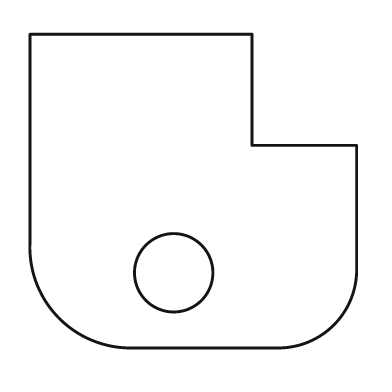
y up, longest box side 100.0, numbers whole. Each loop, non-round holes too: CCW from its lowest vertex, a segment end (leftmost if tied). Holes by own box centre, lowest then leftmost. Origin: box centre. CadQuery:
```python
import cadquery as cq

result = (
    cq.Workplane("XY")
    .moveTo(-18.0, -48.0)
    .lineTo(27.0, -48.0)
    .threePointArc((43.0, -41.0), (50.0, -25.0))
    .lineTo(50.0, 14.0)
    .lineTo(18.0, 14.0)
    .lineTo(18.0, 48.0)
    .lineTo(-50.0, 48.0)
    .lineTo(-50.0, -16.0)
    .threePointArc((-41.0, -39.0), (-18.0, -48.0))
    .close()
    .moveTo(-6.0, -25.0)
    .circle(12.0)
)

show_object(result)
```